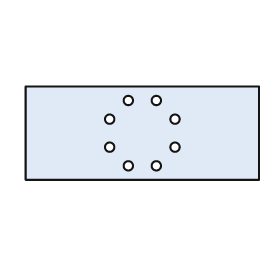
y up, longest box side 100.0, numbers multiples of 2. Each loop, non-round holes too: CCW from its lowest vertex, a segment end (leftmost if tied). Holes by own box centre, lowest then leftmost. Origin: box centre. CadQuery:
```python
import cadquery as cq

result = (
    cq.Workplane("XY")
    .moveTo(-50.0, -20.0)
    .lineTo(50.0, -20.0)
    .lineTo(50.0, 20.0)
    .lineTo(-50.0, 20.0)
    .close()
    .moveTo(-6.0, -14.0)
    .circle(2.0)
    .moveTo(6.0, -14.0)
    .circle(2.0)
    .moveTo(-14.0, -6.0)
    .circle(2.0)
    .moveTo(14.0, -6.0)
    .circle(2.0)
    .moveTo(-14.0, 6.0)
    .circle(2.0)
    .moveTo(14.0, 6.0)
    .circle(2.0)
    .moveTo(-6.0, 14.0)
    .circle(2.0)
    .moveTo(6.0, 14.0)
    .circle(2.0)
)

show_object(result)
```